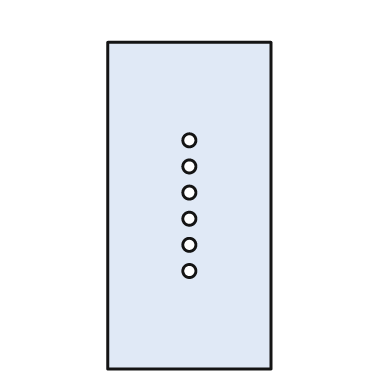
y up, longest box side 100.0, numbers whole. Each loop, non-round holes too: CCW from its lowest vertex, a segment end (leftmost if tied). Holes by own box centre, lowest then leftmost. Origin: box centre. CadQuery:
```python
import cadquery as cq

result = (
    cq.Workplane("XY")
    .moveTo(-25.0, -50.0)
    .lineTo(25.0, -50.0)
    .lineTo(25.0, 50.0)
    .lineTo(-25.0, 50.0)
    .close()
    .moveTo(0.0, -20.0)
    .circle(2.0)
    .moveTo(0.0, -12.0)
    .circle(2.0)
    .moveTo(0.0, -4.0)
    .circle(2.0)
    .moveTo(0.0, 4.0)
    .circle(2.0)
    .moveTo(0.0, 12.0)
    .circle(2.0)
    .moveTo(0.0, 20.0)
    .circle(2.0)
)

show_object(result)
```